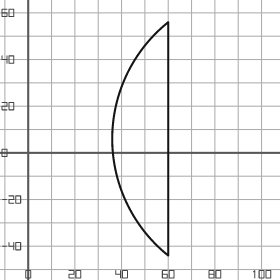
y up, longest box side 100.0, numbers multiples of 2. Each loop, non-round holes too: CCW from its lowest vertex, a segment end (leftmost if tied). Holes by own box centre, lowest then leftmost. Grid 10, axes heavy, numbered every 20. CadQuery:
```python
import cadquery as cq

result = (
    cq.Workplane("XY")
    .moveTo(60.0, -44.0)
    .lineTo(60.0, 56.0)
    .threePointArc((36.0, 6.0), (60.0, -44.0))
    .close()
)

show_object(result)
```